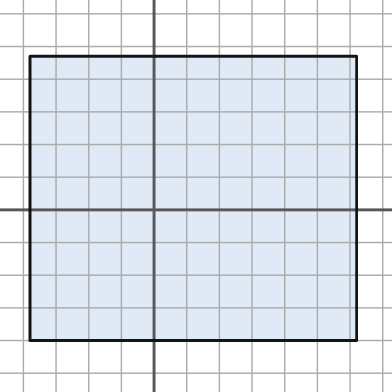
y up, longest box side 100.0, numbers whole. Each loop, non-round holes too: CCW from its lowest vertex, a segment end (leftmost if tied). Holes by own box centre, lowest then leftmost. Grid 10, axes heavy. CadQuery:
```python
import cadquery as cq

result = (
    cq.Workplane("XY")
    .moveTo(-38.0, -40.0)
    .lineTo(62.0, -40.0)
    .lineTo(62.0, 47.0)
    .lineTo(-38.0, 47.0)
    .close()
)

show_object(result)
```